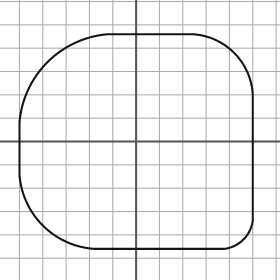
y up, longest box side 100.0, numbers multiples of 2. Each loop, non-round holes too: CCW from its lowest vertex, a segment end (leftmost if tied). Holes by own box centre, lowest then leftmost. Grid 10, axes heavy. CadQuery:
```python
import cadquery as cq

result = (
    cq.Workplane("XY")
    .moveTo(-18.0, -46.0)
    .lineTo(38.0, -46.0)
    .threePointArc((46.0, -42.0), (50.0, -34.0))
    .lineTo(50.0, 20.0)
    .threePointArc((42.0, 38.0), (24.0, 46.0))
    .lineTo(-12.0, 46.0)
    .threePointArc((-38.0, 34.0), (-50.0, 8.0))
    .lineTo(-50.0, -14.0)
    .threePointArc((-40.0, -36.0), (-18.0, -46.0))
    .close()
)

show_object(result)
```